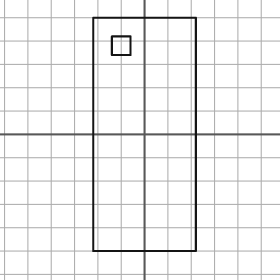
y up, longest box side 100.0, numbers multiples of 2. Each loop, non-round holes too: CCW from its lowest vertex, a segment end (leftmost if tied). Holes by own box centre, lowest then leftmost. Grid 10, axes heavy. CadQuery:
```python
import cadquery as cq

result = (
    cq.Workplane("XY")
    .moveTo(-22.0, -50.0)
    .lineTo(22.0, -50.0)
    .lineTo(22.0, 50.0)
    .lineTo(-22.0, 50.0)
    .close()
    .moveTo(-14.0, 34.0)
    .lineTo(-6.0, 34.0)
    .lineTo(-6.0, 42.0)
    .lineTo(-14.0, 42.0)
    .close()
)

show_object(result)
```